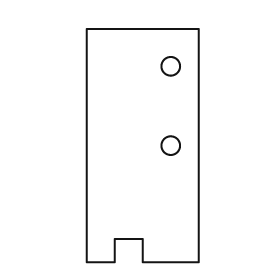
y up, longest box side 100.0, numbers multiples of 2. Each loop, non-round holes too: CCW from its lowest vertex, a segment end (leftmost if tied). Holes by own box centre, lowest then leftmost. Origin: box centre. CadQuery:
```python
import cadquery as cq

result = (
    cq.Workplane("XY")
    .moveTo(-24.0, -50.0)
    .lineTo(-12.0, -50.0)
    .lineTo(-12.0, -40.0)
    .lineTo(0.0, -40.0)
    .lineTo(0.0, -50.0)
    .lineTo(24.0, -50.0)
    .lineTo(24.0, 50.0)
    .lineTo(-24.0, 50.0)
    .close()
    .moveTo(12.0, 0.0)
    .circle(4.0)
    .moveTo(12.0, 34.0)
    .circle(4.0)
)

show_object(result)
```